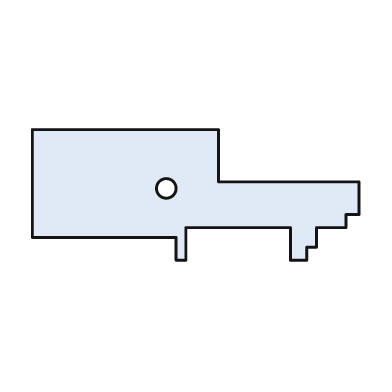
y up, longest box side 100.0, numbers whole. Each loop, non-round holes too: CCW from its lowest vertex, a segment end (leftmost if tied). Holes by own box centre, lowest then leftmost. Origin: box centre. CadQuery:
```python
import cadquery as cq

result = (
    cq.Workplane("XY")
    .moveTo(-6.0, -20.0)
    .lineTo(-3.0, -20.0)
    .lineTo(-3.0, -10.0)
    .lineTo(29.0, -10.0)
    .lineTo(29.0, -20.0)
    .lineTo(34.0, -20.0)
    .lineTo(34.0, -16.0)
    .lineTo(37.0, -16.0)
    .lineTo(37.0, -10.0)
    .lineTo(46.0, -10.0)
    .lineTo(46.0, -6.0)
    .lineTo(50.0, -6.0)
    .lineTo(50.0, 4.0)
    .lineTo(7.0, 4.0)
    .lineTo(7.0, 20.0)
    .lineTo(-50.0, 20.0)
    .lineTo(-50.0, -13.0)
    .lineTo(-6.0, -13.0)
    .close()
    .moveTo(-9.0, 2.0)
    .circle(3.0)
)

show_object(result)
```